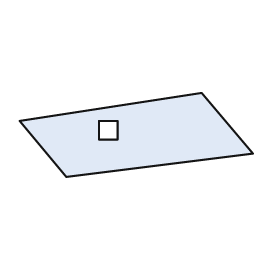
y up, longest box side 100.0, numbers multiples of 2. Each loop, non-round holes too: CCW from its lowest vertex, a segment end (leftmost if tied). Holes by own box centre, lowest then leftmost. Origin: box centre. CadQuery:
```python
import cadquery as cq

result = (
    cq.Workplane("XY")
    .moveTo(-30.0, -18.0)
    .lineTo(50.0, -8.0)
    .lineTo(28.0, 18.0)
    .lineTo(-50.0, 6.0)
    .close()
    .moveTo(-16.0, -2.0)
    .lineTo(-8.0, -2.0)
    .lineTo(-8.0, 6.0)
    .lineTo(-16.0, 6.0)
    .close()
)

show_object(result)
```